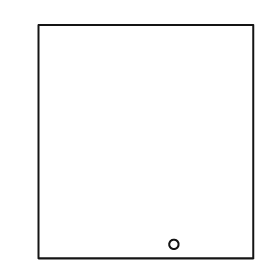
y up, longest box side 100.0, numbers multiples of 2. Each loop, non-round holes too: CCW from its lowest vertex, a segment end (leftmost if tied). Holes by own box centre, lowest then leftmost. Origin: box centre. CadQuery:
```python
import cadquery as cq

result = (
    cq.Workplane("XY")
    .moveTo(-46.0, -50.0)
    .lineTo(46.0, -50.0)
    .lineTo(46.0, 50.0)
    .lineTo(-46.0, 50.0)
    .close()
    .moveTo(12.0, -44.0)
    .circle(2.0)
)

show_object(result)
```